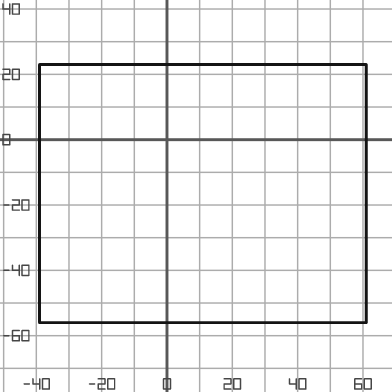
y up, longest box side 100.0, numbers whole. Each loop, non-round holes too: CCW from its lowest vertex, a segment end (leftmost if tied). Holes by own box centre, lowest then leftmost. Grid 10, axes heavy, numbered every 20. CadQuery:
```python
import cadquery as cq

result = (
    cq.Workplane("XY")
    .moveTo(-39.0, -56.0)
    .lineTo(61.0, -56.0)
    .lineTo(61.0, 23.0)
    .lineTo(-39.0, 23.0)
    .close()
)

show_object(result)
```